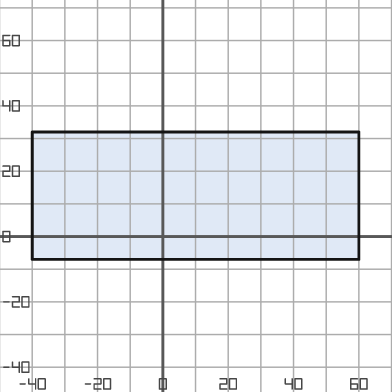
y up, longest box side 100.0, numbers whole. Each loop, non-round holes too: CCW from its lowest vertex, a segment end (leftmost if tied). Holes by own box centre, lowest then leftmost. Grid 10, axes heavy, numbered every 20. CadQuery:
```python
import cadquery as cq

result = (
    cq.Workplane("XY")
    .moveTo(-40.0, -7.0)
    .lineTo(60.0, -7.0)
    .lineTo(60.0, 32.0)
    .lineTo(-40.0, 32.0)
    .close()
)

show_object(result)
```